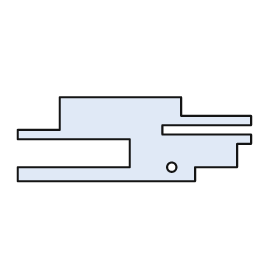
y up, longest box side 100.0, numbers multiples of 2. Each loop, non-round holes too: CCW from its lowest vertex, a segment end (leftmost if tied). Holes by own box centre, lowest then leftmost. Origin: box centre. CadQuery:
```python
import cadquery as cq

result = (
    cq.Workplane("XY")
    .moveTo(-50.0, -18.0)
    .lineTo(26.0, -18.0)
    .lineTo(26.0, -12.0)
    .lineTo(44.0, -12.0)
    .lineTo(44.0, -2.0)
    .lineTo(50.0, -2.0)
    .lineTo(50.0, 2.0)
    .lineTo(12.0, 2.0)
    .lineTo(12.0, 6.0)
    .lineTo(50.0, 6.0)
    .lineTo(50.0, 10.0)
    .lineTo(20.0, 10.0)
    .lineTo(20.0, 18.0)
    .lineTo(-32.0, 18.0)
    .lineTo(-32.0, 4.0)
    .lineTo(-50.0, 4.0)
    .lineTo(-50.0, 0.0)
    .lineTo(-2.0, 0.0)
    .lineTo(-2.0, -12.0)
    .lineTo(-50.0, -12.0)
    .close()
    .moveTo(16.0, -12.0)
    .circle(2.0)
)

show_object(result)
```